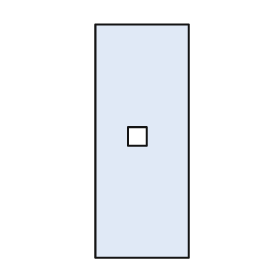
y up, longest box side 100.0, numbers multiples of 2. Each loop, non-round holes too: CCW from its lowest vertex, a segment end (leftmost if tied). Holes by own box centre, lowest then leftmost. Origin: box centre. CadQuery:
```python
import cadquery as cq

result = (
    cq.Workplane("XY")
    .moveTo(-20.0, -50.0)
    .lineTo(20.0, -50.0)
    .lineTo(20.0, 50.0)
    .lineTo(-20.0, 50.0)
    .close()
    .moveTo(-6.0, -2.0)
    .lineTo(2.0, -2.0)
    .lineTo(2.0, 6.0)
    .lineTo(-6.0, 6.0)
    .close()
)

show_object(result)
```